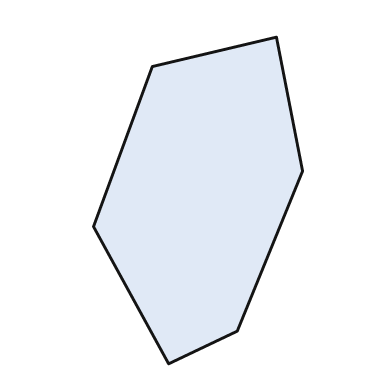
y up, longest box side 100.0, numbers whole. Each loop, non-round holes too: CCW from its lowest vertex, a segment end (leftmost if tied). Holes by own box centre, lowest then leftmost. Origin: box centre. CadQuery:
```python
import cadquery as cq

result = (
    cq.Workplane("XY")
    .moveTo(-9.0, -50.0)
    .lineTo(12.0, -40.0)
    .lineTo(32.0, 9.0)
    .lineTo(24.0, 50.0)
    .lineTo(-14.0, 41.0)
    .lineTo(-32.0, -8.0)
    .close()
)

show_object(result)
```